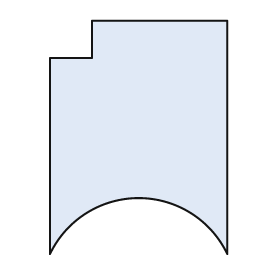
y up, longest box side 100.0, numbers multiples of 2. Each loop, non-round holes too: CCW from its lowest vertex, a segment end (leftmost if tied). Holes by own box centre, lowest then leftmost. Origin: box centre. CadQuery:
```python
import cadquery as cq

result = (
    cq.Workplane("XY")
    .moveTo(-38.0, -50.0)
    .threePointArc((0.0, -26.0), (38.0, -50.0))
    .lineTo(38.0, 50.0)
    .lineTo(-20.0, 50.0)
    .lineTo(-20.0, 34.0)
    .lineTo(-38.0, 34.0)
    .close()
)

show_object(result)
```